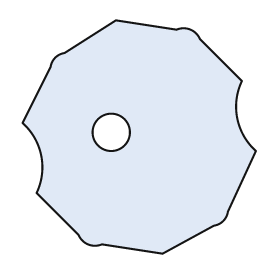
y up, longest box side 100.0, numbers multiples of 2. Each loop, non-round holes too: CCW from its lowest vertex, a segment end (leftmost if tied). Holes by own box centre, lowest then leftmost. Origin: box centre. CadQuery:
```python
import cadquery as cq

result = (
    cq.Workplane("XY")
    .moveTo(10.0, -50.0)
    .lineTo(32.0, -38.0)
    .threePointArc((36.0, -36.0), (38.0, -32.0))
    .lineTo(50.0, -6.0)
    .threePointArc((42.0, 8.0), (44.0, 24.0))
    .lineTo(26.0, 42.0)
    .threePointArc((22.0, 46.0), (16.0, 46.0))
    .lineTo(-10.0, 50.0)
    .lineTo(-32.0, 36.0)
    .threePointArc((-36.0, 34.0), (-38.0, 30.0))
    .lineTo(-50.0, 6.0)
    .threePointArc((-42.0, -8.0), (-44.0, -24.0))
    .lineTo(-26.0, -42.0)
    .threePointArc((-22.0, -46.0), (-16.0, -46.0))
    .close()
    .moveTo(-12.0, 2.0)
    .circle(8.0)
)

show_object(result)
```